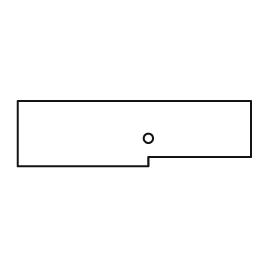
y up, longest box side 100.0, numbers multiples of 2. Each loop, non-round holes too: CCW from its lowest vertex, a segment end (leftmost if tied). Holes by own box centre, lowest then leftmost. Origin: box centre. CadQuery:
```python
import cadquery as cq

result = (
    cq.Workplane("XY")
    .moveTo(-50.0, -14.0)
    .lineTo(6.0, -14.0)
    .lineTo(6.0, -10.0)
    .lineTo(50.0, -10.0)
    .lineTo(50.0, 14.0)
    .lineTo(-50.0, 14.0)
    .close()
    .moveTo(6.0, -2.0)
    .circle(2.0)
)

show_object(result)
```